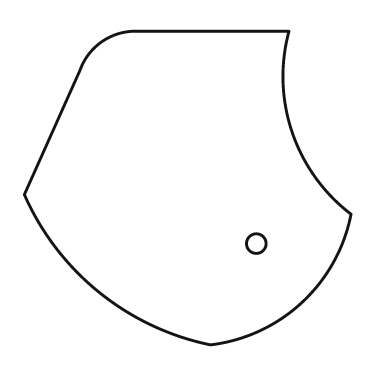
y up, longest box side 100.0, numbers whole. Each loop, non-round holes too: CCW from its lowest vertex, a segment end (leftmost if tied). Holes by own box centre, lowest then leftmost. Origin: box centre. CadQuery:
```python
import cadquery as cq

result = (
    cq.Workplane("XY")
    .moveTo(7.0, -48.0)
    .threePointArc((35.0, -35.0), (50.0, -8.0))
    .threePointArc((32.0, 17.0), (31.0, 48.0))
    .lineTo(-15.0, 48.0)
    .threePointArc((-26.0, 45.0), (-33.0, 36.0))
    .lineTo(-50.0, -2.0)
    .threePointArc((-27.0, -32.0), (7.0, -48.0))
    .close()
    .moveTo(21.0, -17.0)
    .circle(3.0)
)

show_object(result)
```